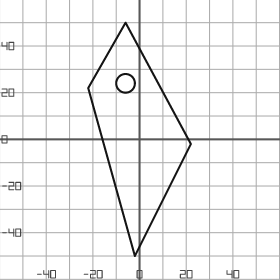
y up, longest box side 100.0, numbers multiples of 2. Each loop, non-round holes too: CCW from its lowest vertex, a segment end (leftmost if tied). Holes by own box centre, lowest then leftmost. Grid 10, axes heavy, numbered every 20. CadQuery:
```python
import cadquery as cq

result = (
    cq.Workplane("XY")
    .moveTo(-2.0, -50.0)
    .lineTo(22.0, -2.0)
    .lineTo(-6.0, 50.0)
    .lineTo(-22.0, 22.0)
    .close()
    .moveTo(-6.0, 24.0)
    .circle(4.0)
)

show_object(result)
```